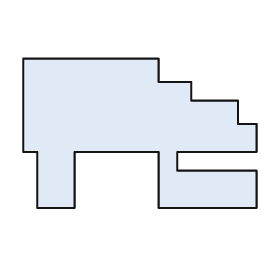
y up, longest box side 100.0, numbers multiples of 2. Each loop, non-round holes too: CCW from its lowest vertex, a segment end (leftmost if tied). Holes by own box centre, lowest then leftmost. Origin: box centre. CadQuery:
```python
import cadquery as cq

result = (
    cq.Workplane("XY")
    .moveTo(-44.0, -32.0)
    .lineTo(-28.0, -32.0)
    .lineTo(-28.0, -8.0)
    .lineTo(8.0, -8.0)
    .lineTo(8.0, -32.0)
    .lineTo(50.0, -32.0)
    .lineTo(50.0, -16.0)
    .lineTo(16.0, -16.0)
    .lineTo(16.0, -8.0)
    .lineTo(50.0, -8.0)
    .lineTo(50.0, 4.0)
    .lineTo(42.0, 4.0)
    .lineTo(42.0, 14.0)
    .lineTo(22.0, 14.0)
    .lineTo(22.0, 22.0)
    .lineTo(8.0, 22.0)
    .lineTo(8.0, 32.0)
    .lineTo(-50.0, 32.0)
    .lineTo(-50.0, -8.0)
    .lineTo(-44.0, -8.0)
    .close()
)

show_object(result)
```